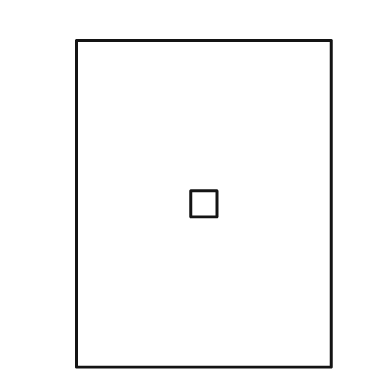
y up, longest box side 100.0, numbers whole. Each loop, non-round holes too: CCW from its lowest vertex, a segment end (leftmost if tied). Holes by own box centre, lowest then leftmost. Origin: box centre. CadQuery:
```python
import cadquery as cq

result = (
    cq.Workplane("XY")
    .moveTo(-39.0, -50.0)
    .lineTo(39.0, -50.0)
    .lineTo(39.0, 50.0)
    .lineTo(-39.0, 50.0)
    .close()
    .moveTo(-4.0, -4.0)
    .lineTo(4.0, -4.0)
    .lineTo(4.0, 4.0)
    .lineTo(-4.0, 4.0)
    .close()
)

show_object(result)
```